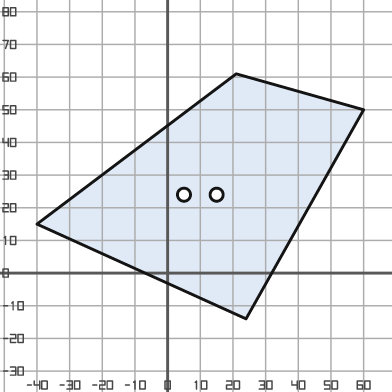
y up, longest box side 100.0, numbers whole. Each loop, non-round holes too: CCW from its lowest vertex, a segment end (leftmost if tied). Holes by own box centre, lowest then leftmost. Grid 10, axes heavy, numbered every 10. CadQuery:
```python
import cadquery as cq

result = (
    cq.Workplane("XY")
    .moveTo(24.0, -14.0)
    .lineTo(60.0, 50.0)
    .lineTo(21.0, 61.0)
    .lineTo(-40.0, 15.0)
    .close()
    .moveTo(5.0, 24.0)
    .circle(2.0)
    .moveTo(15.0, 24.0)
    .circle(2.0)
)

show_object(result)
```